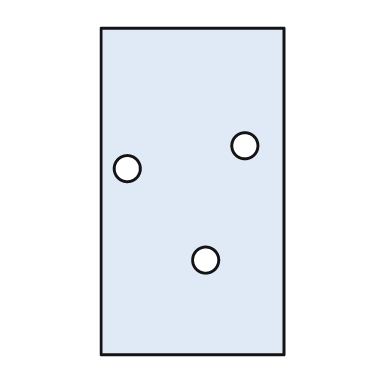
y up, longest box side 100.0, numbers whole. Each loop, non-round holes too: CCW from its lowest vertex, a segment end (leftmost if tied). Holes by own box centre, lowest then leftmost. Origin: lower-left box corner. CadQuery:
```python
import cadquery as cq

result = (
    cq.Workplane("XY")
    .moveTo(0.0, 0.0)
    .lineTo(56.0, 0.0)
    .lineTo(56.0, 100.0)
    .lineTo(0.0, 100.0)
    .close()
    .moveTo(32.0, 29.0)
    .circle(4.0)
    .moveTo(8.0, 57.0)
    .circle(4.0)
    .moveTo(44.0, 64.0)
    .circle(4.0)
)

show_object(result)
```